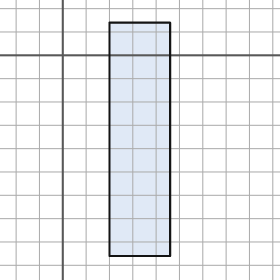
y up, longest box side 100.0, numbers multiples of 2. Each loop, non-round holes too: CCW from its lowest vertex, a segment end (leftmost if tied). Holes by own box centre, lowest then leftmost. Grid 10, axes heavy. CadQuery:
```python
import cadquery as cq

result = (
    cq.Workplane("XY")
    .moveTo(20.0, -86.0)
    .lineTo(46.0, -86.0)
    .lineTo(46.0, 14.0)
    .lineTo(20.0, 14.0)
    .close()
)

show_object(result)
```